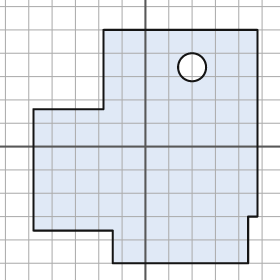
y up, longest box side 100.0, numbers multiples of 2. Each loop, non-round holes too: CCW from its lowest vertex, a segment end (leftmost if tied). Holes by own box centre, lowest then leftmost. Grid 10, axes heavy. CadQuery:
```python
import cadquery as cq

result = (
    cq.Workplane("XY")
    .moveTo(-14.0, -50.0)
    .lineTo(44.0, -50.0)
    .lineTo(44.0, -30.0)
    .lineTo(48.0, -30.0)
    .lineTo(48.0, 50.0)
    .lineTo(-18.0, 50.0)
    .lineTo(-18.0, 16.0)
    .lineTo(-48.0, 16.0)
    .lineTo(-48.0, -36.0)
    .lineTo(-14.0, -36.0)
    .close()
    .moveTo(20.0, 34.0)
    .circle(6.0)
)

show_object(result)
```